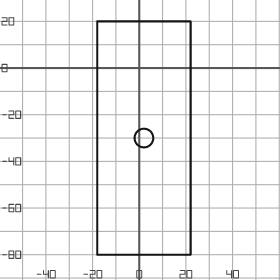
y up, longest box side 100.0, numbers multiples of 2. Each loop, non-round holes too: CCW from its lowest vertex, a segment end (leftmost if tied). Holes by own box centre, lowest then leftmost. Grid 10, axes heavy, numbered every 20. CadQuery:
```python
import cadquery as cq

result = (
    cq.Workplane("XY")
    .moveTo(-18.0, -80.0)
    .lineTo(22.0, -80.0)
    .lineTo(22.0, 20.0)
    .lineTo(-18.0, 20.0)
    .close()
    .moveTo(2.0, -30.0)
    .circle(4.0)
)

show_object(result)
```